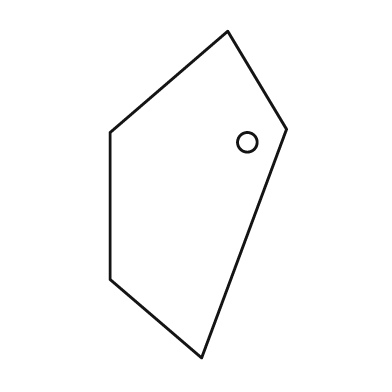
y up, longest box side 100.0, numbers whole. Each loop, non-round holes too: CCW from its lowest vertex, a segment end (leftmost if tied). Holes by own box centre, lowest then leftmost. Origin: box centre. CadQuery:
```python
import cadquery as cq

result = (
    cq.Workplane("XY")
    .moveTo(1.0, -50.0)
    .lineTo(27.0, 20.0)
    .lineTo(9.0, 50.0)
    .lineTo(-27.0, 19.0)
    .lineTo(-27.0, -26.0)
    .close()
    .moveTo(15.0, 16.0)
    .circle(3.0)
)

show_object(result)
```